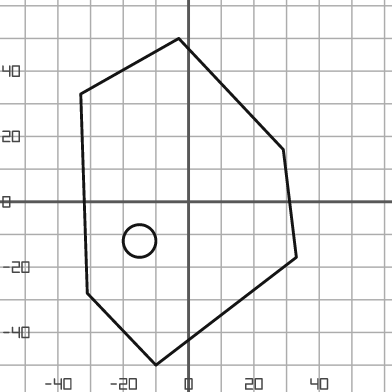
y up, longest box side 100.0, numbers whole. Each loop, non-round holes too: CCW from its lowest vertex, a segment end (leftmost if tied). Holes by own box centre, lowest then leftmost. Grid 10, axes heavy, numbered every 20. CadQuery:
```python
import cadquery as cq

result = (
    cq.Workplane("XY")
    .moveTo(-10.0, -50.0)
    .lineTo(33.0, -17.0)
    .lineTo(29.0, 16.0)
    .lineTo(-3.0, 50.0)
    .lineTo(-33.0, 33.0)
    .lineTo(-31.0, -28.0)
    .close()
    .moveTo(-15.0, -12.0)
    .circle(5.0)
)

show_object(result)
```